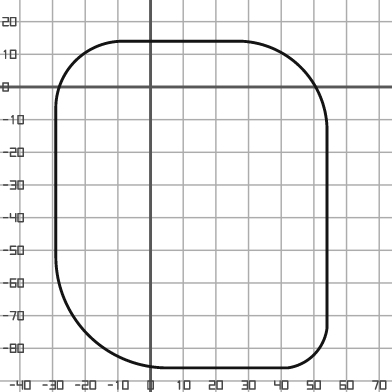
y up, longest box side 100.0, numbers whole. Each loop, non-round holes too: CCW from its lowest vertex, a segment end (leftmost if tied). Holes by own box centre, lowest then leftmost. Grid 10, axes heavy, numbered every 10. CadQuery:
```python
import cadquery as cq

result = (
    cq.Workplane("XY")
    .moveTo(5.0, -86.0)
    .lineTo(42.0, -86.0)
    .threePointArc((50.0, -82.0), (54.0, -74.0))
    .lineTo(54.0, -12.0)
    .threePointArc((46.0, 6.0), (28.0, 14.0))
    .lineTo(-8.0, 14.0)
    .threePointArc((-23.0, 8.0), (-29.0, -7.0))
    .lineTo(-29.0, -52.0)
    .threePointArc((-19.0, -76.0), (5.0, -86.0))
    .close()
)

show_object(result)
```